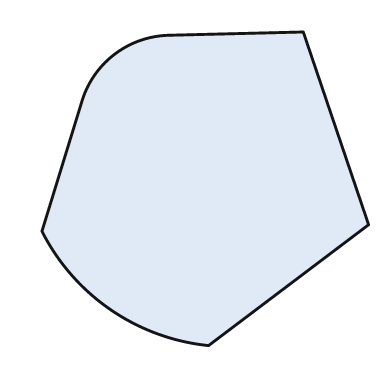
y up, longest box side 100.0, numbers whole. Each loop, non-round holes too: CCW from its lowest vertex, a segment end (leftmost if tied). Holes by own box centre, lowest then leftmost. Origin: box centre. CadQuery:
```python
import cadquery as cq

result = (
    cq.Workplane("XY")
    .moveTo(1.0, -48.0)
    .lineTo(50.0, -11.0)
    .lineTo(30.0, 48.0)
    .lineTo(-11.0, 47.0)
    .threePointArc((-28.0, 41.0), (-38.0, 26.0))
    .lineTo(-50.0, -13.0)
    .threePointArc((-29.0, -37.0), (1.0, -48.0))
    .close()
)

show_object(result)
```